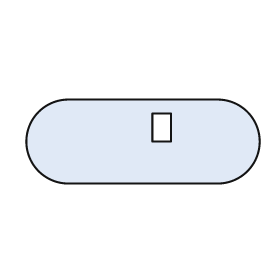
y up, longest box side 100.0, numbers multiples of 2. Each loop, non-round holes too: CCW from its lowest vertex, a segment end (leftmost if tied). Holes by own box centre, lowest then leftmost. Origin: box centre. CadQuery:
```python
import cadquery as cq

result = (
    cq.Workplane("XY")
    .moveTo(-32.0, -18.0)
    .lineTo(32.0, -18.0)
    .threePointArc((50.0, 0.0), (32.0, 18.0))
    .lineTo(-32.0, 18.0)
    .threePointArc((-50.0, 0.0), (-32.0, -18.0))
    .close()
    .moveTo(4.0, 0.0)
    .lineTo(12.0, 0.0)
    .lineTo(12.0, 12.0)
    .lineTo(4.0, 12.0)
    .close()
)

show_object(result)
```